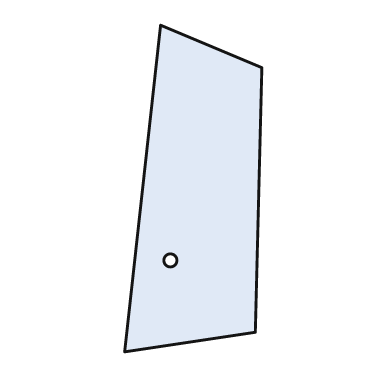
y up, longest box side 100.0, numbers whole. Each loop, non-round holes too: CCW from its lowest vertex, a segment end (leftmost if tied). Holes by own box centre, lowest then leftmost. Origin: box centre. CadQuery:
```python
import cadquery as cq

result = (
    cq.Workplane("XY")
    .moveTo(-21.0, -50.0)
    .lineTo(19.0, -44.0)
    .lineTo(21.0, 37.0)
    .lineTo(-10.0, 50.0)
    .close()
    .moveTo(-7.0, -22.0)
    .circle(2.0)
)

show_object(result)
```